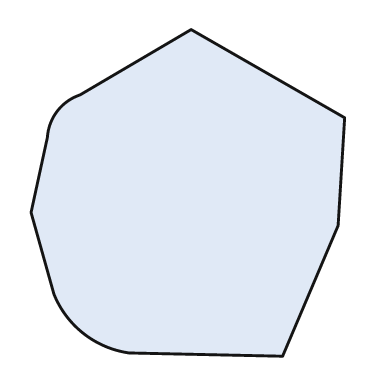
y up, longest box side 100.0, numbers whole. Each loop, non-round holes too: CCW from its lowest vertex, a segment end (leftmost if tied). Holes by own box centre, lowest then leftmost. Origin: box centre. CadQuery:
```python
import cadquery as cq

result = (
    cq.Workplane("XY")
    .moveTo(29.0, -50.0)
    .lineTo(46.0, -10.0)
    .lineTo(48.0, 23.0)
    .lineTo(1.0, 50.0)
    .lineTo(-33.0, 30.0)
    .threePointArc((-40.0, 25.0), (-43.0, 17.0))
    .lineTo(-48.0, -6.0)
    .lineTo(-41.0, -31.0)
    .threePointArc((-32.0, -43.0), (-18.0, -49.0))
    .close()
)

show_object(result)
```